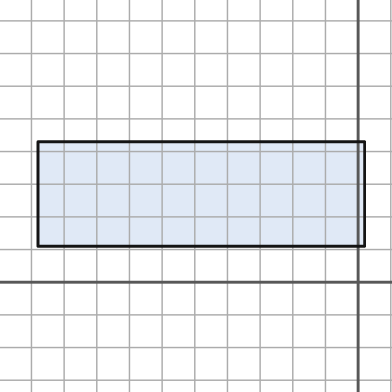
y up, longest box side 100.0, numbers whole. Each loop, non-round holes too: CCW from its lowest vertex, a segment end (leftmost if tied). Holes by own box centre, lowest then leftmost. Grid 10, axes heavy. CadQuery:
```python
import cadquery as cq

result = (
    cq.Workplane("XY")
    .moveTo(-98.0, 11.0)
    .lineTo(2.0, 11.0)
    .lineTo(2.0, 43.0)
    .lineTo(-98.0, 43.0)
    .close()
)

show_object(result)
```